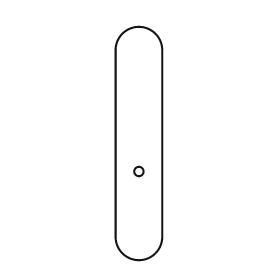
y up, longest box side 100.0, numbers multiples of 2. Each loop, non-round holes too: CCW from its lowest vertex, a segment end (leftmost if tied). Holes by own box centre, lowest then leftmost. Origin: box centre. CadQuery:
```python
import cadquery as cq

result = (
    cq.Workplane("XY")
    .moveTo(-10.0, -40.0)
    .threePointArc((0.0, -50.0), (10.0, -40.0))
    .lineTo(10.0, 40.0)
    .threePointArc((0.0, 50.0), (-10.0, 40.0))
    .close()
    .moveTo(0.0, -12.0)
    .circle(2.0)
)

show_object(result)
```